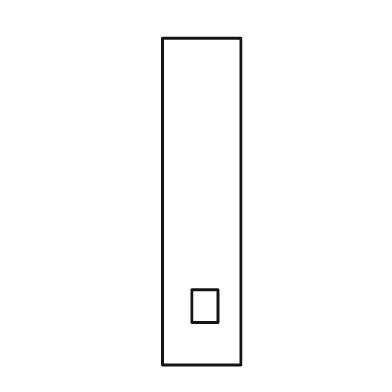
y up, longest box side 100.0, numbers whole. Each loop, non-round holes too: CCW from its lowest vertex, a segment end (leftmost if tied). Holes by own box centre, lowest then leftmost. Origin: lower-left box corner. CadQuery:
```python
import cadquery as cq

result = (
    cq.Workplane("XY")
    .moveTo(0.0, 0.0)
    .lineTo(24.0, 0.0)
    .lineTo(24.0, 100.0)
    .lineTo(0.0, 100.0)
    .close()
    .moveTo(9.0, 13.0)
    .lineTo(17.0, 13.0)
    .lineTo(17.0, 23.0)
    .lineTo(9.0, 23.0)
    .close()
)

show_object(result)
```